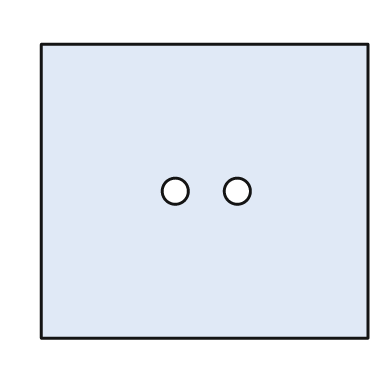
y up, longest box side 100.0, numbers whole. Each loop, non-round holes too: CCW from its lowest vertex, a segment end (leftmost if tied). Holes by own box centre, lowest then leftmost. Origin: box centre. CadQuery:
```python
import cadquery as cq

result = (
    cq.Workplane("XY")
    .moveTo(-50.0, -45.0)
    .lineTo(50.0, -45.0)
    .lineTo(50.0, 45.0)
    .lineTo(-50.0, 45.0)
    .close()
    .moveTo(-9.0, 0.0)
    .circle(4.0)
    .moveTo(10.0, 0.0)
    .circle(4.0)
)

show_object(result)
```